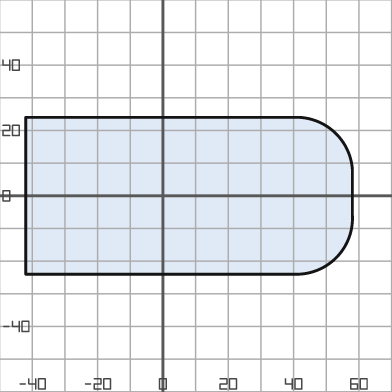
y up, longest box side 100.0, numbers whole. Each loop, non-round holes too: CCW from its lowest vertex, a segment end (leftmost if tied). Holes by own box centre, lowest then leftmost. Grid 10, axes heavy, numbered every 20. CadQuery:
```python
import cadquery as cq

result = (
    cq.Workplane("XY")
    .moveTo(-42.0, -24.0)
    .lineTo(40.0, -24.0)
    .threePointArc((53.0, -19.0), (58.0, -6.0))
    .lineTo(58.0, 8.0)
    .threePointArc((53.0, 19.0), (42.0, 24.0))
    .lineTo(-42.0, 24.0)
    .close()
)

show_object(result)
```